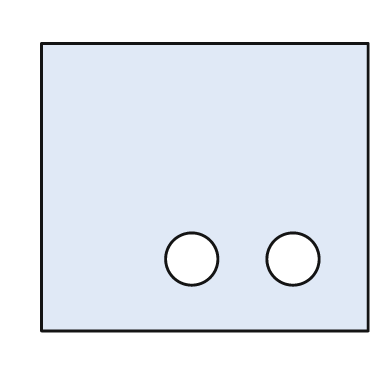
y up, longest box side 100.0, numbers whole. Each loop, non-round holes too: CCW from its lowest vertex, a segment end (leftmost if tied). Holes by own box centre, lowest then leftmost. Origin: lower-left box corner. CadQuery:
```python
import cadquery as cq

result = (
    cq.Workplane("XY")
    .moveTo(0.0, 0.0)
    .lineTo(100.0, 0.0)
    .lineTo(100.0, 88.0)
    .lineTo(0.0, 88.0)
    .close()
    .moveTo(46.0, 22.0)
    .circle(8.0)
    .moveTo(77.0, 22.0)
    .circle(8.0)
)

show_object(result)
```